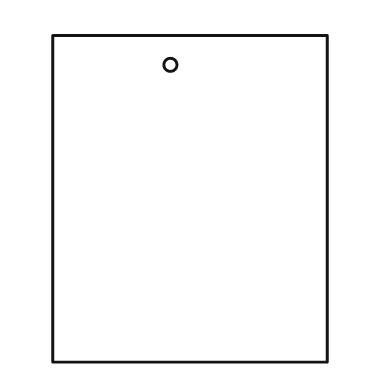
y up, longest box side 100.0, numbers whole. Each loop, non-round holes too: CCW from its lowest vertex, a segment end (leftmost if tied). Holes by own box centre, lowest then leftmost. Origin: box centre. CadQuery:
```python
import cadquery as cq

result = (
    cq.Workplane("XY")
    .moveTo(-42.0, -50.0)
    .lineTo(42.0, -50.0)
    .lineTo(42.0, 50.0)
    .lineTo(-42.0, 50.0)
    .close()
    .moveTo(-6.0, 41.0)
    .circle(2.0)
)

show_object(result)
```